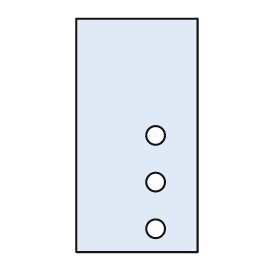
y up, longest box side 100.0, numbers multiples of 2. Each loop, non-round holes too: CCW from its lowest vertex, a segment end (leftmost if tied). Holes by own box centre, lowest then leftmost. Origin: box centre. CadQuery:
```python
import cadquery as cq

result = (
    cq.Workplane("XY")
    .moveTo(-26.0, -50.0)
    .lineTo(26.0, -50.0)
    .lineTo(26.0, 50.0)
    .lineTo(-26.0, 50.0)
    .close()
    .moveTo(8.0, -40.0)
    .circle(4.0)
    .moveTo(8.0, -20.0)
    .circle(4.0)
    .moveTo(8.0, 0.0)
    .circle(4.0)
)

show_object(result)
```